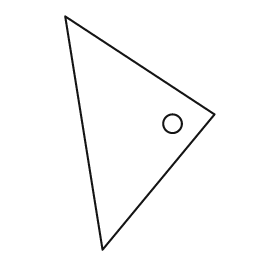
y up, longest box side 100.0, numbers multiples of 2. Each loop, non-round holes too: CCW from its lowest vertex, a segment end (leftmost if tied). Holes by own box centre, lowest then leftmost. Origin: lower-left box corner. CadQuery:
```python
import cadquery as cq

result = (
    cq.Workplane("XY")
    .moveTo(16.0, 0.0)
    .lineTo(64.0, 58.0)
    .lineTo(0.0, 100.0)
    .close()
    .moveTo(46.0, 54.0)
    .circle(4.0)
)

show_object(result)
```